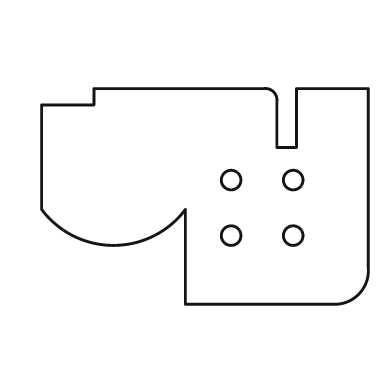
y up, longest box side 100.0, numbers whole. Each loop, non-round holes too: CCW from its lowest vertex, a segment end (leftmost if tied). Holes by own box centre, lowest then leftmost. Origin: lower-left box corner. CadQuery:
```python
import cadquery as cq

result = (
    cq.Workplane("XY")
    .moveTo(44.0, 0.0)
    .lineTo(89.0, 0.0)
    .threePointArc((97.0, 3.0), (100.0, 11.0))
    .lineTo(100.0, 66.0)
    .lineTo(78.0, 66.0)
    .lineTo(78.0, 48.0)
    .lineTo(72.0, 48.0)
    .lineTo(72.0, 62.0)
    .threePointArc((71.0, 65.0), (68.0, 66.0))
    .lineTo(16.0, 66.0)
    .lineTo(16.0, 61.0)
    .lineTo(0.0, 61.0)
    .lineTo(0.0, 29.0)
    .threePointArc((22.0, 18.0), (44.0, 29.0))
    .close()
    .moveTo(58.0, 21.0)
    .circle(3.0)
    .moveTo(77.0, 21.0)
    .circle(3.0)
    .moveTo(58.0, 38.0)
    .circle(3.0)
    .moveTo(77.0, 38.0)
    .circle(3.0)
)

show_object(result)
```